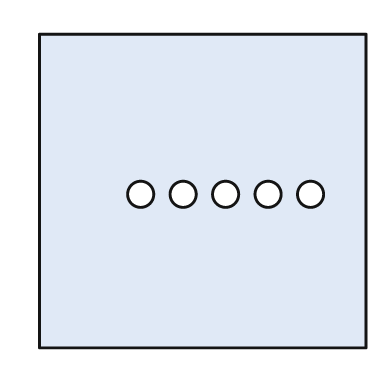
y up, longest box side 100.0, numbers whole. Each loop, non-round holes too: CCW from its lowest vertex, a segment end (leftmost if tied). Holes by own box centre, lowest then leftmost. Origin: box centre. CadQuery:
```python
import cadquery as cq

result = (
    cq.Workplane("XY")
    .moveTo(-50.0, -48.0)
    .lineTo(50.0, -48.0)
    .lineTo(50.0, 48.0)
    .lineTo(-50.0, 48.0)
    .close()
    .moveTo(-19.0, -1.0)
    .circle(4.0)
    .moveTo(-6.0, -1.0)
    .circle(4.0)
    .moveTo(7.0, -1.0)
    .circle(4.0)
    .moveTo(20.0, -1.0)
    .circle(4.0)
    .moveTo(33.0, -1.0)
    .circle(4.0)
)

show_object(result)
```